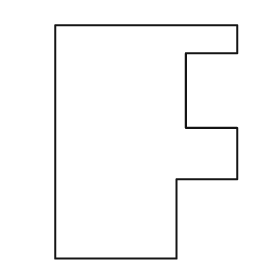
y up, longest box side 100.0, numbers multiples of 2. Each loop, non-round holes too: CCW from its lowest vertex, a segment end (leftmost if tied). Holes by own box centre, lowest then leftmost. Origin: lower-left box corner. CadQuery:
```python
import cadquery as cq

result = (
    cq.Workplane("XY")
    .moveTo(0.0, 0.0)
    .lineTo(52.0, 0.0)
    .lineTo(52.0, 34.0)
    .lineTo(78.0, 34.0)
    .lineTo(78.0, 56.0)
    .lineTo(56.0, 56.0)
    .lineTo(56.0, 88.0)
    .lineTo(78.0, 88.0)
    .lineTo(78.0, 100.0)
    .lineTo(0.0, 100.0)
    .close()
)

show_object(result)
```